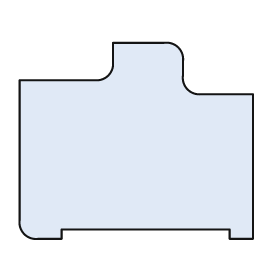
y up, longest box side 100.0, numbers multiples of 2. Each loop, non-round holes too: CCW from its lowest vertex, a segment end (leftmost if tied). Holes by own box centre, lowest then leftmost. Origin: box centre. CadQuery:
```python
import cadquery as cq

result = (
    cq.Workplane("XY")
    .moveTo(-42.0, -42.0)
    .lineTo(-32.0, -42.0)
    .lineTo(-32.0, -38.0)
    .lineTo(40.0, -38.0)
    .lineTo(40.0, -42.0)
    .lineTo(50.0, -42.0)
    .lineTo(50.0, 20.0)
    .lineTo(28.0, 20.0)
    .threePointArc((22.0, 22.0), (20.0, 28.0))
    .lineTo(20.0, 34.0)
    .threePointArc((18.0, 40.0), (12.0, 42.0))
    .lineTo(-10.0, 42.0)
    .lineTo(-10.0, 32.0)
    .threePointArc((-12.0, 28.0), (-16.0, 26.0))
    .lineTo(-50.0, 26.0)
    .lineTo(-50.0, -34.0)
    .threePointArc((-48.0, -40.0), (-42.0, -42.0))
    .close()
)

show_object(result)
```